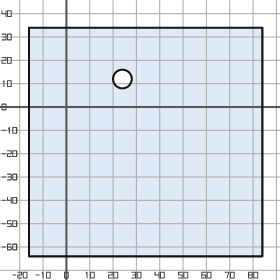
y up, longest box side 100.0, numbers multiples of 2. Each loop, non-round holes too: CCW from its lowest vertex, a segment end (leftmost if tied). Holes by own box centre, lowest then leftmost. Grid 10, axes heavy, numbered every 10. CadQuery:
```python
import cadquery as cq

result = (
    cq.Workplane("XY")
    .moveTo(-16.0, -64.0)
    .lineTo(84.0, -64.0)
    .lineTo(84.0, 34.0)
    .lineTo(-16.0, 34.0)
    .close()
    .moveTo(24.0, 12.0)
    .circle(4.0)
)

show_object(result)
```